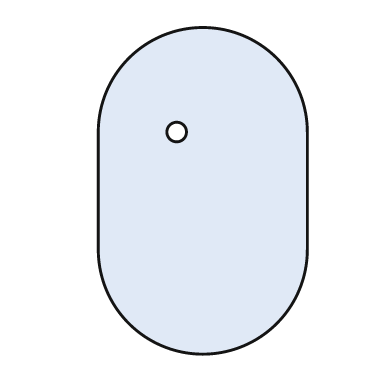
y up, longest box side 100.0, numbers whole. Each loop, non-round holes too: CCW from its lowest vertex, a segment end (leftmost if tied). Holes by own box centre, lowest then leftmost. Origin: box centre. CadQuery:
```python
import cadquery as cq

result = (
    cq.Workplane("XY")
    .moveTo(-32.0, -18.0)
    .threePointArc((0.0, -50.0), (32.0, -18.0))
    .lineTo(32.0, 18.0)
    .threePointArc((0.0, 50.0), (-32.0, 18.0))
    .close()
    .moveTo(-8.0, 18.0)
    .circle(3.0)
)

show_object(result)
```